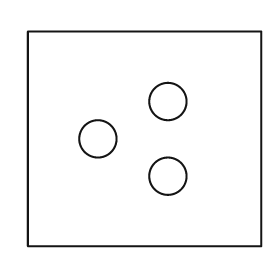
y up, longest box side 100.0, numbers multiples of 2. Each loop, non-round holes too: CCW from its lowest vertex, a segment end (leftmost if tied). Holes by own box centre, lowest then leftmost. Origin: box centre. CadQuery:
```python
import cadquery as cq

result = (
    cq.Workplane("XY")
    .moveTo(-50.0, -46.0)
    .lineTo(50.0, -46.0)
    .lineTo(50.0, 46.0)
    .lineTo(-50.0, 46.0)
    .close()
    .moveTo(10.0, -16.0)
    .circle(8.0)
    .moveTo(-20.0, 0.0)
    .circle(8.0)
    .moveTo(10.0, 16.0)
    .circle(8.0)
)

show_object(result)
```